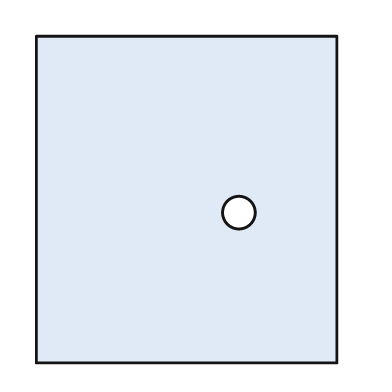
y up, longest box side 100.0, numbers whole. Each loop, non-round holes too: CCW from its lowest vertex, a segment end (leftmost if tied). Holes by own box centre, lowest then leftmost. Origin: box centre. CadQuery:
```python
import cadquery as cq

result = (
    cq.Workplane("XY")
    .moveTo(-46.0, -50.0)
    .lineTo(46.0, -50.0)
    .lineTo(46.0, 50.0)
    .lineTo(-46.0, 50.0)
    .close()
    .moveTo(16.0, -4.0)
    .circle(5.0)
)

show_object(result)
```